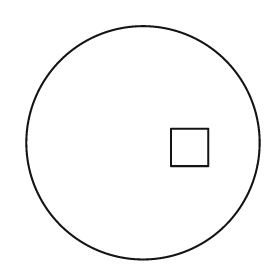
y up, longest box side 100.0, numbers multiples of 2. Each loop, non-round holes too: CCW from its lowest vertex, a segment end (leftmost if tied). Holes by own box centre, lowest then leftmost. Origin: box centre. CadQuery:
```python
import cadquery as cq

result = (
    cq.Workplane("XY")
    .moveTo(0.0, 0.0)
    .circle(50.0)
    .moveTo(12.0, -10.0)
    .lineTo(28.0, -10.0)
    .lineTo(28.0, 6.0)
    .lineTo(12.0, 6.0)
    .close()
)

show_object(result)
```